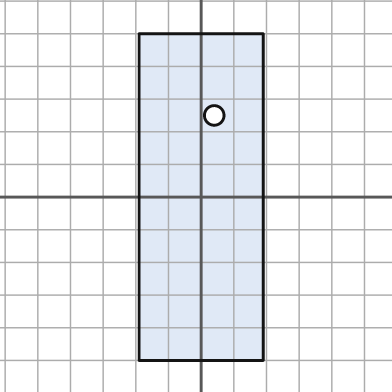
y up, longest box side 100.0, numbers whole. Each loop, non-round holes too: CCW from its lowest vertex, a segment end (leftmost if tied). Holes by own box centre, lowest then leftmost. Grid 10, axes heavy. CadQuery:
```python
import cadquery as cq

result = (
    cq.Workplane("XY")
    .moveTo(-19.0, -50.0)
    .lineTo(19.0, -50.0)
    .lineTo(19.0, 50.0)
    .lineTo(-19.0, 50.0)
    .close()
    .moveTo(4.0, 25.0)
    .circle(3.0)
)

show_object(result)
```